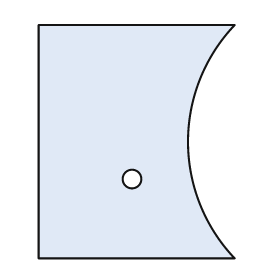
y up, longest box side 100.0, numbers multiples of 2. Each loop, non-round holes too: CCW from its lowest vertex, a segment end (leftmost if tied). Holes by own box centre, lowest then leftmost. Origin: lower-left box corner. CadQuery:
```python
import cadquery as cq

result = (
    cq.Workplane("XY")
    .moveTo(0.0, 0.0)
    .lineTo(84.0, 0.0)
    .threePointArc((64.0, 50.0), (84.0, 100.0))
    .lineTo(0.0, 100.0)
    .close()
    .moveTo(40.0, 34.0)
    .circle(4.0)
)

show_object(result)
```